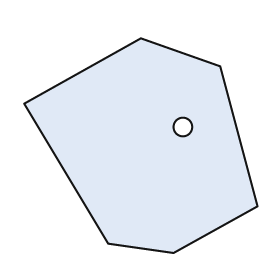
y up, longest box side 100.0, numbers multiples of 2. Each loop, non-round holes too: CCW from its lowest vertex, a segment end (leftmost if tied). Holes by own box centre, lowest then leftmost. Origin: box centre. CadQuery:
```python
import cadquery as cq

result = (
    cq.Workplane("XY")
    .moveTo(14.0, -46.0)
    .lineTo(50.0, -26.0)
    .lineTo(34.0, 34.0)
    .lineTo(0.0, 46.0)
    .lineTo(-50.0, 18.0)
    .lineTo(-14.0, -42.0)
    .close()
    .moveTo(18.0, 8.0)
    .circle(4.0)
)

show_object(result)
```